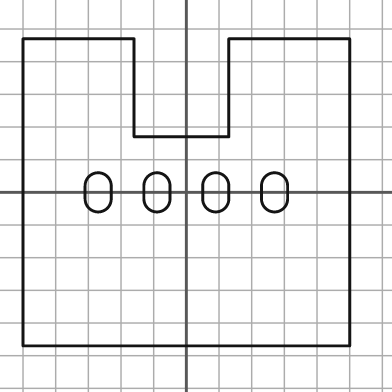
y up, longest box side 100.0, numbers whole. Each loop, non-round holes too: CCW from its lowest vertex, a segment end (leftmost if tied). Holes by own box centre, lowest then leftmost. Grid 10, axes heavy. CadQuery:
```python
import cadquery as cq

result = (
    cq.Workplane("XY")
    .moveTo(-50.0, -47.0)
    .lineTo(50.0, -47.0)
    .lineTo(50.0, 47.0)
    .lineTo(13.0, 47.0)
    .lineTo(13.0, 17.0)
    .lineTo(-16.0, 17.0)
    .lineTo(-16.0, 47.0)
    .lineTo(-50.0, 47.0)
    .close()
    .moveTo(-31.0, -2.0)
    .threePointArc((-27.0, -6.0), (-23.0, -2.0))
    .lineTo(-23.0, 2.0)
    .threePointArc((-27.0, 6.0), (-31.0, 2.0))
    .close()
    .moveTo(-13.0, -2.0)
    .threePointArc((-9.0, -6.0), (-5.0, -2.0))
    .lineTo(-5.0, 2.0)
    .threePointArc((-9.0, 6.0), (-13.0, 2.0))
    .close()
    .moveTo(5.0, -2.0)
    .threePointArc((9.0, -6.0), (13.0, -2.0))
    .lineTo(13.0, 2.0)
    .threePointArc((9.0, 6.0), (5.0, 2.0))
    .close()
    .moveTo(23.0, -2.0)
    .threePointArc((27.0, -6.0), (31.0, -2.0))
    .lineTo(31.0, 2.0)
    .threePointArc((27.0, 6.0), (23.0, 2.0))
    .close()
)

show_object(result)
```